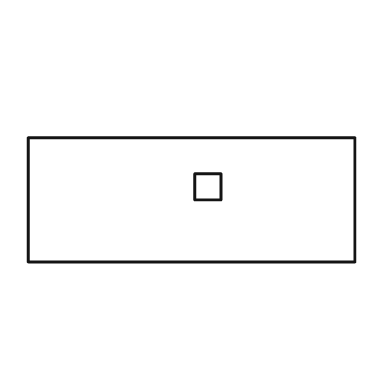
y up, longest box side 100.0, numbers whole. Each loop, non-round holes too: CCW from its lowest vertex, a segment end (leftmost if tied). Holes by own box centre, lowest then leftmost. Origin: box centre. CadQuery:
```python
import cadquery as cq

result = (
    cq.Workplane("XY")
    .moveTo(-50.0, -19.0)
    .lineTo(50.0, -19.0)
    .lineTo(50.0, 19.0)
    .lineTo(-50.0, 19.0)
    .close()
    .moveTo(1.0, 0.0)
    .lineTo(9.0, 0.0)
    .lineTo(9.0, 8.0)
    .lineTo(1.0, 8.0)
    .close()
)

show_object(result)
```